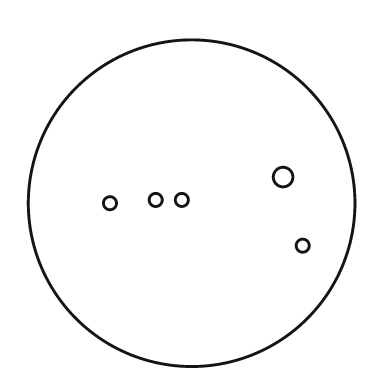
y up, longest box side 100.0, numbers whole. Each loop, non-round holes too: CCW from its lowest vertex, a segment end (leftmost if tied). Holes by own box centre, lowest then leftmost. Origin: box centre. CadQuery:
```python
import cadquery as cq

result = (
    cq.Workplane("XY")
    .moveTo(0.0, 0.0)
    .circle(50.0)
    .moveTo(34.0, -13.0)
    .circle(2.0)
    .moveTo(-25.0, 0.0)
    .circle(2.0)
    .moveTo(-11.0, 1.0)
    .circle(2.0)
    .moveTo(-3.0, 1.0)
    .circle(2.0)
    .moveTo(28.0, 8.0)
    .circle(3.0)
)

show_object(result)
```